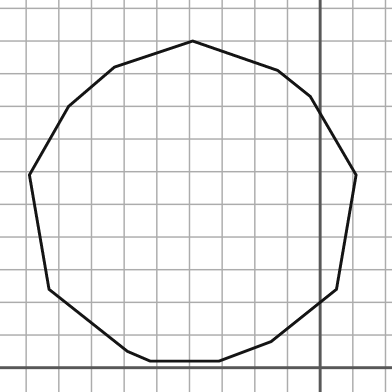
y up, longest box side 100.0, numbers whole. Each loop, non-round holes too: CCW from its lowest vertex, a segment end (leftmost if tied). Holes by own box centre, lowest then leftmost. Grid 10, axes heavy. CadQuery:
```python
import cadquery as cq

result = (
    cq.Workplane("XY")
    .moveTo(-52.0, 2.0)
    .lineTo(-31.0, 2.0)
    .lineTo(-15.0, 8.0)
    .lineTo(5.0, 24.0)
    .lineTo(11.0, 59.0)
    .lineTo(-3.0, 83.0)
    .lineTo(-13.0, 91.0)
    .lineTo(-39.0, 100.0)
    .lineTo(-63.0, 92.0)
    .lineTo(-77.0, 80.0)
    .lineTo(-89.0, 59.0)
    .lineTo(-83.0, 24.0)
    .lineTo(-59.0, 5.0)
    .close()
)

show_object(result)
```